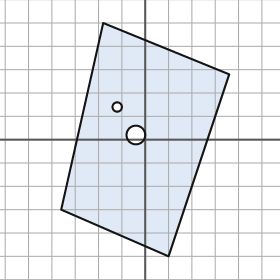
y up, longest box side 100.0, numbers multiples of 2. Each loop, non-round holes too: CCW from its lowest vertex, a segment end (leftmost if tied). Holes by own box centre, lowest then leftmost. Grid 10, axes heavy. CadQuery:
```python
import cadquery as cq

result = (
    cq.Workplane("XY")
    .moveTo(10.0, -50.0)
    .lineTo(36.0, 28.0)
    .lineTo(-18.0, 50.0)
    .lineTo(-36.0, -30.0)
    .close()
    .moveTo(-4.0, 2.0)
    .circle(4.0)
    .moveTo(-12.0, 14.0)
    .circle(2.0)
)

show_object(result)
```